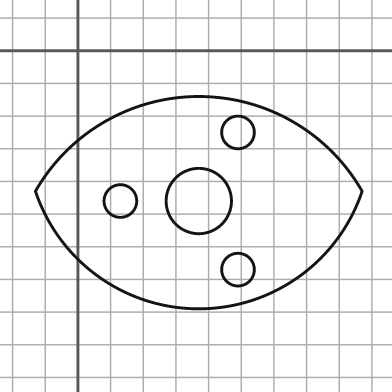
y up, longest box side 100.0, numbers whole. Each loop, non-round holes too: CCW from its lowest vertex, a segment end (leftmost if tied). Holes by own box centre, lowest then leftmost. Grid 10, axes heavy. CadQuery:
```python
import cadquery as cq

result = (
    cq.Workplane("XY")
    .moveTo(-13.0, -43.0)
    .threePointArc((37.0, -79.0), (87.0, -43.0))
    .threePointArc((37.0, -14.0), (-13.0, -43.0))
    .close()
    .moveTo(49.0, -67.0)
    .circle(5.0)
    .moveTo(13.0, -46.0)
    .circle(5.0)
    .moveTo(37.0, -46.0)
    .circle(10.0)
    .moveTo(49.0, -25.0)
    .circle(5.0)
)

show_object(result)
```